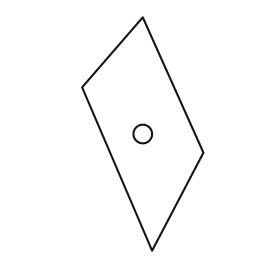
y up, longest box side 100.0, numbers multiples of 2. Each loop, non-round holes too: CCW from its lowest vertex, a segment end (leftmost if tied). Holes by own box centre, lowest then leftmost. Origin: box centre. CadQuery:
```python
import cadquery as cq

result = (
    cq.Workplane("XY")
    .moveTo(4.0, -50.0)
    .lineTo(26.0, -8.0)
    .lineTo(0.0, 50.0)
    .lineTo(-26.0, 20.0)
    .close()
    .moveTo(0.0, 0.0)
    .circle(4.0)
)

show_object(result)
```